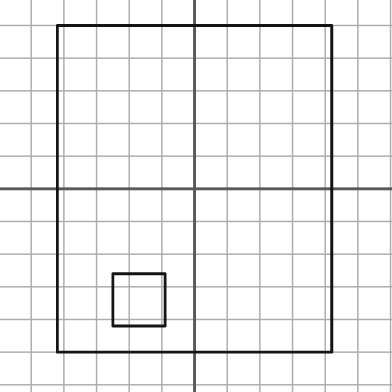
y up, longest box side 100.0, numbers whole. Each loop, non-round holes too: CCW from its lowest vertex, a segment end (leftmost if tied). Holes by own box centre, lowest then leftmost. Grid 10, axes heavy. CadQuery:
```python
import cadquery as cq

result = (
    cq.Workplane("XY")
    .moveTo(-42.0, -50.0)
    .lineTo(42.0, -50.0)
    .lineTo(42.0, 50.0)
    .lineTo(-42.0, 50.0)
    .close()
    .moveTo(-25.0, -42.0)
    .lineTo(-9.0, -42.0)
    .lineTo(-9.0, -26.0)
    .lineTo(-25.0, -26.0)
    .close()
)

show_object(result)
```